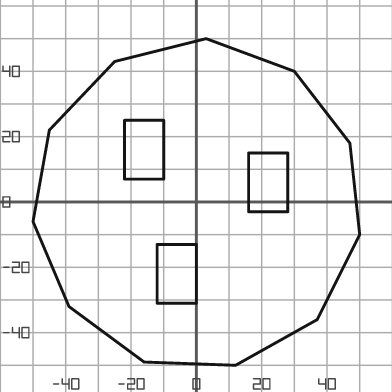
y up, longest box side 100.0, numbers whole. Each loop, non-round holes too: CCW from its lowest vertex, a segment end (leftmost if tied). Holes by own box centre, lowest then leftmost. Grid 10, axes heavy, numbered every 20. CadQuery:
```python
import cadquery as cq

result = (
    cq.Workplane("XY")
    .moveTo(12.0, -50.0)
    .lineTo(37.0, -36.0)
    .lineTo(50.0, -10.0)
    .lineTo(47.0, 18.0)
    .lineTo(30.0, 40.0)
    .lineTo(3.0, 50.0)
    .lineTo(-25.0, 43.0)
    .lineTo(-45.0, 22.0)
    .lineTo(-50.0, -6.0)
    .lineTo(-39.0, -32.0)
    .lineTo(-16.0, -49.0)
    .close()
    .moveTo(-12.0, -31.0)
    .lineTo(0.0, -31.0)
    .lineTo(0.0, -13.0)
    .lineTo(-12.0, -13.0)
    .close()
    .moveTo(16.0, -3.0)
    .lineTo(28.0, -3.0)
    .lineTo(28.0, 15.0)
    .lineTo(16.0, 15.0)
    .close()
    .moveTo(-22.0, 7.0)
    .lineTo(-10.0, 7.0)
    .lineTo(-10.0, 25.0)
    .lineTo(-22.0, 25.0)
    .close()
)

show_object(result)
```